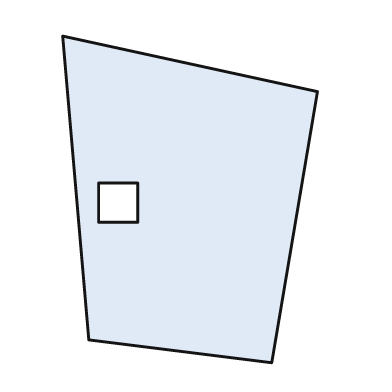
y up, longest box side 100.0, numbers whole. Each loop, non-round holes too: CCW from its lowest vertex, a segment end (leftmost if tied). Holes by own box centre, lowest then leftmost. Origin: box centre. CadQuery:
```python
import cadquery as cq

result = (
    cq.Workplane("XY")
    .moveTo(25.0, -50.0)
    .lineTo(39.0, 33.0)
    .lineTo(-39.0, 50.0)
    .lineTo(-31.0, -43.0)
    .close()
    .moveTo(-28.0, -7.0)
    .lineTo(-16.0, -7.0)
    .lineTo(-16.0, 5.0)
    .lineTo(-28.0, 5.0)
    .close()
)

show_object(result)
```